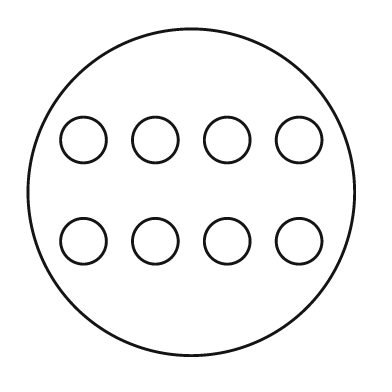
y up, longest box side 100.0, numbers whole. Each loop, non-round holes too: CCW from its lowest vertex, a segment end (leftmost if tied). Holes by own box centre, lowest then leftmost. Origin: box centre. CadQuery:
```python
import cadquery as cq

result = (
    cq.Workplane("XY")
    .moveTo(0.0, 0.0)
    .circle(50.0)
    .moveTo(-33.0, -15.0)
    .circle(7.0)
    .moveTo(-11.0, -15.0)
    .circle(7.0)
    .moveTo(11.0, -15.0)
    .circle(7.0)
    .moveTo(33.0, -15.0)
    .circle(7.0)
    .moveTo(-33.0, 16.0)
    .circle(7.0)
    .moveTo(-11.0, 16.0)
    .circle(7.0)
    .moveTo(11.0, 16.0)
    .circle(7.0)
    .moveTo(33.0, 16.0)
    .circle(7.0)
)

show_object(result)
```